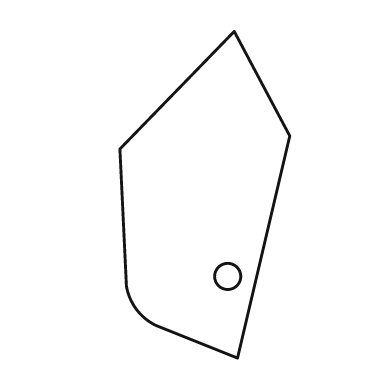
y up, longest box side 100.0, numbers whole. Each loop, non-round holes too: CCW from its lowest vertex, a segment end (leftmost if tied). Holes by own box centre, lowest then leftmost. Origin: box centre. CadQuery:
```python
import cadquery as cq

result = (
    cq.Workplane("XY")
    .moveTo(10.0, -50.0)
    .lineTo(26.0, 18.0)
    .lineTo(9.0, 50.0)
    .lineTo(-26.0, 14.0)
    .lineTo(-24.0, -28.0)
    .threePointArc((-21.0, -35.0), (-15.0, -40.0))
    .close()
    .moveTo(7.0, -25.0)
    .circle(4.0)
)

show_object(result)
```